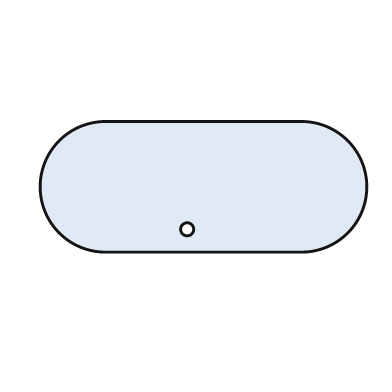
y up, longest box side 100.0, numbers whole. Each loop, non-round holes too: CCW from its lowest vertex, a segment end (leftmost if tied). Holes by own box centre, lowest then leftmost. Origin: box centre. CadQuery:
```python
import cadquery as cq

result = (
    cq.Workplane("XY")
    .moveTo(-30.0, -20.0)
    .lineTo(30.0, -20.0)
    .threePointArc((50.0, 0.0), (30.0, 20.0))
    .lineTo(-30.0, 20.0)
    .threePointArc((-50.0, 0.0), (-30.0, -20.0))
    .close()
    .moveTo(-5.0, -13.0)
    .circle(2.0)
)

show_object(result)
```